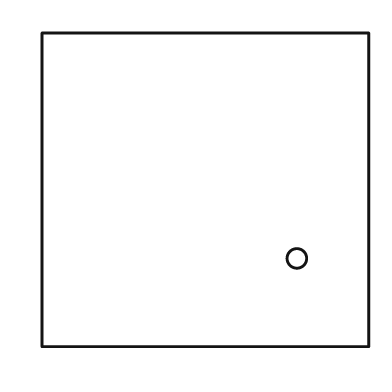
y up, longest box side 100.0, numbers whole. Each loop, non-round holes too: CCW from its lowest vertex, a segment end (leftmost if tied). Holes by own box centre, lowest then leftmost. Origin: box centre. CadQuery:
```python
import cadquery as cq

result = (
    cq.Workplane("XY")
    .moveTo(-50.0, -48.0)
    .lineTo(50.0, -48.0)
    .lineTo(50.0, 48.0)
    .lineTo(-50.0, 48.0)
    .close()
    .moveTo(28.0, -21.0)
    .circle(3.0)
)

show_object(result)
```